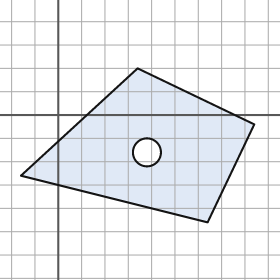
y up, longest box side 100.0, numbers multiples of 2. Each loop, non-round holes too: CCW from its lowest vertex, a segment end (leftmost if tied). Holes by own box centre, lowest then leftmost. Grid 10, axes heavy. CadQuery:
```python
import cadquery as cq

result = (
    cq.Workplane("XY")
    .moveTo(64.0, -46.0)
    .lineTo(84.0, -4.0)
    .lineTo(34.0, 20.0)
    .lineTo(-16.0, -26.0)
    .close()
    .moveTo(38.0, -16.0)
    .circle(6.0)
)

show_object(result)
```